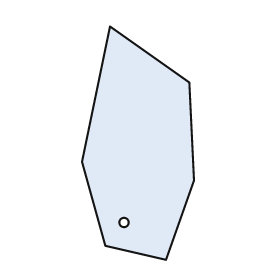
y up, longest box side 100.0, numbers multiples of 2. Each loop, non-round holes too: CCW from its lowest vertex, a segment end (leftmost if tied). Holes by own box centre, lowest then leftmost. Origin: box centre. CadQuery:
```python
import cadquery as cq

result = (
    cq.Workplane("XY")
    .moveTo(12.0, -50.0)
    .lineTo(24.0, -16.0)
    .lineTo(22.0, 26.0)
    .lineTo(-12.0, 50.0)
    .lineTo(-24.0, -8.0)
    .lineTo(-14.0, -44.0)
    .close()
    .moveTo(-6.0, -34.0)
    .circle(2.0)
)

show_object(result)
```